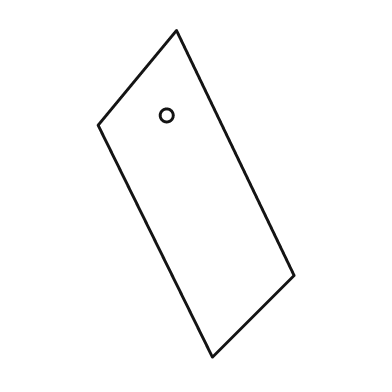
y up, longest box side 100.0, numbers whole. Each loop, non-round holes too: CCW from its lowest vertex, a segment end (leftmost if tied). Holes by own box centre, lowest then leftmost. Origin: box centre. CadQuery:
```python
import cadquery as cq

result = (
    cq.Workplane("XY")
    .moveTo(5.0, -50.0)
    .lineTo(30.0, -25.0)
    .lineTo(-6.0, 50.0)
    .lineTo(-30.0, 21.0)
    .close()
    .moveTo(-9.0, 24.0)
    .circle(2.0)
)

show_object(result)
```